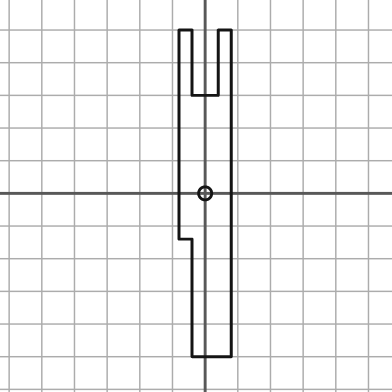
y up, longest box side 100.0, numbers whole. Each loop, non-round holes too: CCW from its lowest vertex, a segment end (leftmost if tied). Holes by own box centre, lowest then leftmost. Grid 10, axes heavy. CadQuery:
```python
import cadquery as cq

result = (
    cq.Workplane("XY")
    .moveTo(-4.0, -50.0)
    .lineTo(8.0, -50.0)
    .lineTo(8.0, 50.0)
    .lineTo(4.0, 50.0)
    .lineTo(4.0, 30.0)
    .lineTo(-4.0, 30.0)
    .lineTo(-4.0, 50.0)
    .lineTo(-8.0, 50.0)
    .lineTo(-8.0, -14.0)
    .lineTo(-4.0, -14.0)
    .close()
    .moveTo(0.0, 0.0)
    .circle(2.0)
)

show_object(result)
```